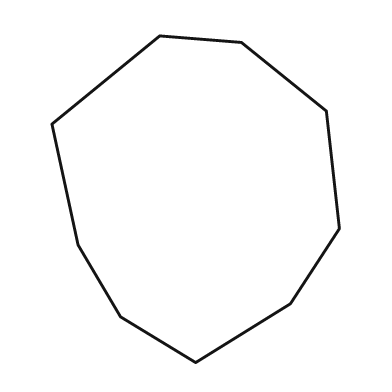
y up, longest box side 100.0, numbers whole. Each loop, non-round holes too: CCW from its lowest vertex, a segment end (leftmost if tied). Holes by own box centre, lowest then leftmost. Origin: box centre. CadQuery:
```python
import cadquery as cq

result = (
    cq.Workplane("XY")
    .moveTo(0.0, -50.0)
    .lineTo(29.0, -32.0)
    .lineTo(44.0, -9.0)
    .lineTo(40.0, 27.0)
    .lineTo(14.0, 48.0)
    .lineTo(-11.0, 50.0)
    .lineTo(-44.0, 23.0)
    .lineTo(-36.0, -14.0)
    .lineTo(-23.0, -36.0)
    .close()
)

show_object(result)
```